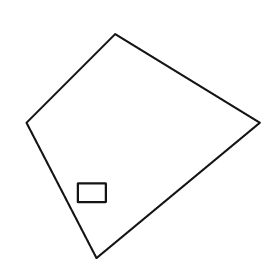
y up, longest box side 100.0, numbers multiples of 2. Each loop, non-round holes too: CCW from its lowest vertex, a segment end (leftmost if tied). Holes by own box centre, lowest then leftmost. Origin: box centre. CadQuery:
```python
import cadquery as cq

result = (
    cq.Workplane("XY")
    .moveTo(-20.0, -48.0)
    .lineTo(50.0, 10.0)
    .lineTo(-12.0, 48.0)
    .lineTo(-50.0, 10.0)
    .close()
    .moveTo(-28.0, -24.0)
    .lineTo(-16.0, -24.0)
    .lineTo(-16.0, -16.0)
    .lineTo(-28.0, -16.0)
    .close()
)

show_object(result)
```